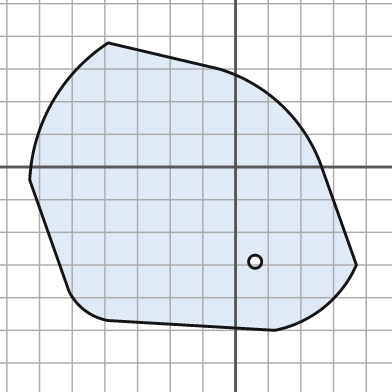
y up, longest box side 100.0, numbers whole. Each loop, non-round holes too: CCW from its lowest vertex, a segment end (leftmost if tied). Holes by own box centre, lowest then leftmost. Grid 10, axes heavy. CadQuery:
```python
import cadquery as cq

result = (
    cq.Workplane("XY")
    .moveTo(12.0, -50.0)
    .threePointArc((27.0, -43.0), (37.0, -30.0))
    .lineTo(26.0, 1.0)
    .threePointArc((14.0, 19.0), (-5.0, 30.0))
    .lineTo(-39.0, 38.0)
    .threePointArc((-56.0, 20.0), (-63.0, -4.0))
    .lineTo(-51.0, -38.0)
    .threePointArc((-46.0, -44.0), (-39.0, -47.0))
    .close()
    .moveTo(6.0, -29.0)
    .circle(2.0)
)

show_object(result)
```